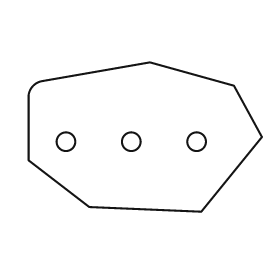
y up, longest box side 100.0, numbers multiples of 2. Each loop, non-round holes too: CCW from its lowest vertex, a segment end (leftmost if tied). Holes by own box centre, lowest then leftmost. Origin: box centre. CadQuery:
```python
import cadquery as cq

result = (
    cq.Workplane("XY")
    .moveTo(24.0, -32.0)
    .lineTo(50.0, 0.0)
    .lineTo(38.0, 22.0)
    .lineTo(2.0, 32.0)
    .lineTo(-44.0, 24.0)
    .threePointArc((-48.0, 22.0), (-50.0, 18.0))
    .lineTo(-50.0, -10.0)
    .lineTo(-24.0, -30.0)
    .close()
    .moveTo(-34.0, -2.0)
    .circle(4.0)
    .moveTo(-6.0, -2.0)
    .circle(4.0)
    .moveTo(22.0, -2.0)
    .circle(4.0)
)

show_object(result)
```